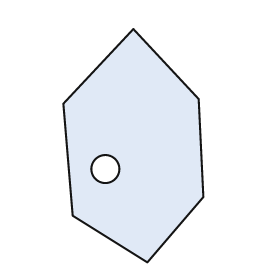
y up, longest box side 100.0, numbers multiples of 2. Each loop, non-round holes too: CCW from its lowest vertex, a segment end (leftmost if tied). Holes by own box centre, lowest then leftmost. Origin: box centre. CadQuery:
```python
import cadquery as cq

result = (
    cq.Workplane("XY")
    .moveTo(6.0, -50.0)
    .lineTo(30.0, -22.0)
    .lineTo(28.0, 20.0)
    .lineTo(0.0, 50.0)
    .lineTo(-30.0, 18.0)
    .lineTo(-26.0, -30.0)
    .close()
    .moveTo(-12.0, -10.0)
    .circle(6.0)
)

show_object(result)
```